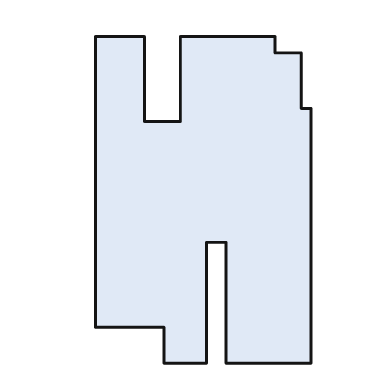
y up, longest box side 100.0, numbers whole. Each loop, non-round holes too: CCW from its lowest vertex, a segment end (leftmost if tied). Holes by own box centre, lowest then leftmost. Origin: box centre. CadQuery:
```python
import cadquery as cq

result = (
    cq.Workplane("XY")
    .moveTo(-12.0, -50.0)
    .lineTo(1.0, -50.0)
    .lineTo(1.0, -13.0)
    .lineTo(7.0, -13.0)
    .lineTo(7.0, -50.0)
    .lineTo(33.0, -50.0)
    .lineTo(33.0, 28.0)
    .lineTo(30.0, 28.0)
    .lineTo(30.0, 45.0)
    .lineTo(22.0, 45.0)
    .lineTo(22.0, 50.0)
    .lineTo(-7.0, 50.0)
    .lineTo(-7.0, 24.0)
    .lineTo(-18.0, 24.0)
    .lineTo(-18.0, 50.0)
    .lineTo(-33.0, 50.0)
    .lineTo(-33.0, -39.0)
    .lineTo(-12.0, -39.0)
    .close()
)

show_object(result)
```